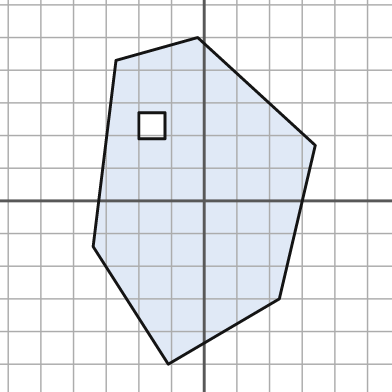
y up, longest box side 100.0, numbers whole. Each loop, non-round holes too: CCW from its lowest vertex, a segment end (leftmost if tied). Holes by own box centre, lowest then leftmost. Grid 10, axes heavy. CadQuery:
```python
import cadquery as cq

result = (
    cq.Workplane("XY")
    .moveTo(-11.0, -50.0)
    .lineTo(23.0, -30.0)
    .lineTo(34.0, 17.0)
    .lineTo(-2.0, 50.0)
    .lineTo(-27.0, 43.0)
    .lineTo(-34.0, -14.0)
    .close()
    .moveTo(-20.0, 19.0)
    .lineTo(-12.0, 19.0)
    .lineTo(-12.0, 27.0)
    .lineTo(-20.0, 27.0)
    .close()
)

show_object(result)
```